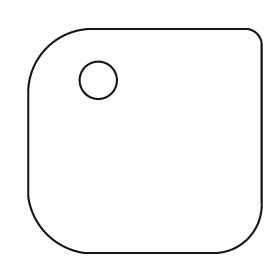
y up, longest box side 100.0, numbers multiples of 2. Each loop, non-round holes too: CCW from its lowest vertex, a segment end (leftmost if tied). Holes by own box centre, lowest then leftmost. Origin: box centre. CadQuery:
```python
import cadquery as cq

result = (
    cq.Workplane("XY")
    .moveTo(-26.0, -48.0)
    .lineTo(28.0, -48.0)
    .threePointArc((44.0, -42.0), (50.0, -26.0))
    .lineTo(50.0, 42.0)
    .threePointArc((48.0, 46.0), (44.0, 48.0))
    .lineTo(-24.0, 48.0)
    .threePointArc((-42.0, 40.0), (-50.0, 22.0))
    .lineTo(-50.0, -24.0)
    .threePointArc((-42.0, -40.0), (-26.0, -48.0))
    .close()
    .moveTo(-20.0, 26.0)
    .circle(8.0)
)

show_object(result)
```